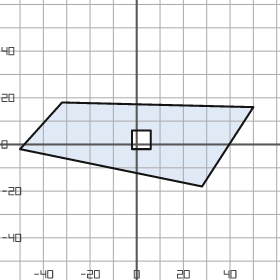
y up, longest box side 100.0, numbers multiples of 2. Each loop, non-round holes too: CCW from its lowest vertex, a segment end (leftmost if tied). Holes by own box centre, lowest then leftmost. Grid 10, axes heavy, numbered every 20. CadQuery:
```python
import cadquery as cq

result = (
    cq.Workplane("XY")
    .moveTo(28.0, -18.0)
    .lineTo(50.0, 16.0)
    .lineTo(-32.0, 18.0)
    .lineTo(-50.0, -2.0)
    .close()
    .moveTo(-2.0, -2.0)
    .lineTo(6.0, -2.0)
    .lineTo(6.0, 6.0)
    .lineTo(-2.0, 6.0)
    .close()
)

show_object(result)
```